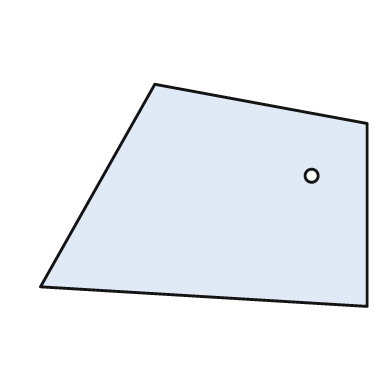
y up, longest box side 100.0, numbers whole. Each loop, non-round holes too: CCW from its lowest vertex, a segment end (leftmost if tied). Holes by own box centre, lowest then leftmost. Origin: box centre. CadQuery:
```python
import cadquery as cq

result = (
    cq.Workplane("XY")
    .moveTo(50.0, -34.0)
    .lineTo(50.0, 22.0)
    .lineTo(-15.0, 34.0)
    .lineTo(-50.0, -28.0)
    .close()
    .moveTo(33.0, 6.0)
    .circle(2.0)
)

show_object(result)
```